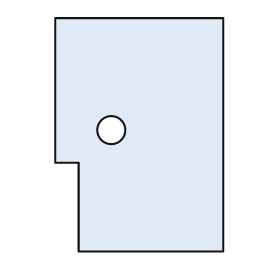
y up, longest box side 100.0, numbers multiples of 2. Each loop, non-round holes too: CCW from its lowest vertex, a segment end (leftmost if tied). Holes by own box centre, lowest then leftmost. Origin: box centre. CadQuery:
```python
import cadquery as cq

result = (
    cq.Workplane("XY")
    .moveTo(-26.0, -50.0)
    .lineTo(36.0, -50.0)
    .lineTo(36.0, 50.0)
    .lineTo(-36.0, 50.0)
    .lineTo(-36.0, -12.0)
    .lineTo(-26.0, -12.0)
    .close()
    .moveTo(-12.0, 2.0)
    .circle(6.0)
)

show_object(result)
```